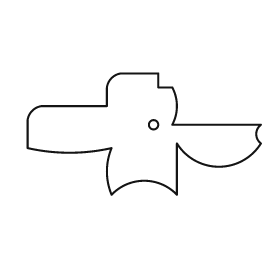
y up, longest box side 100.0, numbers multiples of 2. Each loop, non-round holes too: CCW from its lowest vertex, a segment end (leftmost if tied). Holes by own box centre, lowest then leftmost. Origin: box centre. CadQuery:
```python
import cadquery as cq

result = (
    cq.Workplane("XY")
    .moveTo(-14.0, -26.0)
    .threePointArc((0.0, -20.0), (14.0, -26.0))
    .lineTo(14.0, -4.0)
    .threePointArc((32.0, -14.0), (50.0, -4.0))
    .threePointArc((48.0, 0.0), (50.0, 4.0))
    .lineTo(12.0, 4.0)
    .threePointArc((14.0, 12.0), (12.0, 20.0))
    .lineTo(6.0, 20.0)
    .lineTo(6.0, 26.0)
    .lineTo(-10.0, 26.0)
    .threePointArc((-14.0, 24.0), (-16.0, 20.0))
    .lineTo(-16.0, 12.0)
    .lineTo(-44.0, 12.0)
    .threePointArc((-48.0, 10.0), (-50.0, 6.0))
    .lineTo(-50.0, -6.0)
    .threePointArc((-32.0, -8.0), (-14.0, -6.0))
    .threePointArc((-16.0, -16.0), (-14.0, -26.0))
    .close()
    .moveTo(4.0, 4.0)
    .circle(2.0)
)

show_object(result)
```